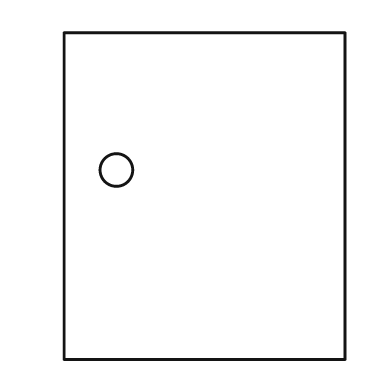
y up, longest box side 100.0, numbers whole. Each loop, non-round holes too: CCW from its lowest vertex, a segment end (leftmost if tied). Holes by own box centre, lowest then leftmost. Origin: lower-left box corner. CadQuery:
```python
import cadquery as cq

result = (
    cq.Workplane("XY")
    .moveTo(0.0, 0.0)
    .lineTo(86.0, 0.0)
    .lineTo(86.0, 100.0)
    .lineTo(0.0, 100.0)
    .close()
    .moveTo(16.0, 58.0)
    .circle(5.0)
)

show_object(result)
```